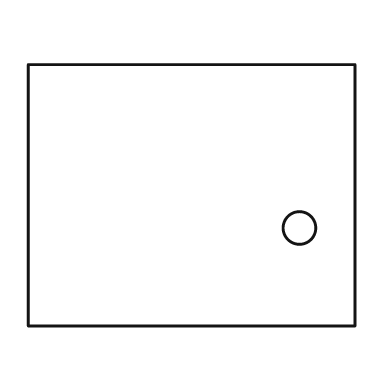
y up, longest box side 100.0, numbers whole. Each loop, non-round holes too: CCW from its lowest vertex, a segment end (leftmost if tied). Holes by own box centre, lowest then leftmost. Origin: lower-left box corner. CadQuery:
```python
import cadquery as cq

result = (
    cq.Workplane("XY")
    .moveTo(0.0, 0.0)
    .lineTo(100.0, 0.0)
    .lineTo(100.0, 80.0)
    .lineTo(0.0, 80.0)
    .close()
    .moveTo(83.0, 30.0)
    .circle(5.0)
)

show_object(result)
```